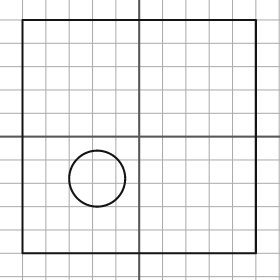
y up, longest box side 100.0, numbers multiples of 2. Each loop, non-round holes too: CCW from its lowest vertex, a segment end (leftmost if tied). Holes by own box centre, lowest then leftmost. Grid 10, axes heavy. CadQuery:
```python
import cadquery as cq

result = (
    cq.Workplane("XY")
    .moveTo(-50.0, -50.0)
    .lineTo(50.0, -50.0)
    .lineTo(50.0, 50.0)
    .lineTo(-50.0, 50.0)
    .close()
    .moveTo(-18.0, -18.0)
    .circle(12.0)
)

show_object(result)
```